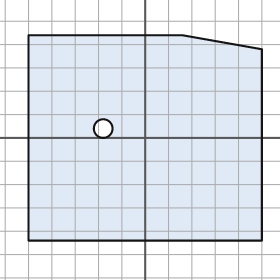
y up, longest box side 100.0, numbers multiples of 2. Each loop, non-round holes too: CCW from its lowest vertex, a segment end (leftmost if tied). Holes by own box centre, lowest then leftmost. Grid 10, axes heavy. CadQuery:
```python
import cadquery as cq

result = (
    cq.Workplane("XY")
    .moveTo(-50.0, -44.0)
    .lineTo(50.0, -44.0)
    .lineTo(50.0, 38.0)
    .lineTo(16.0, 44.0)
    .lineTo(-50.0, 44.0)
    .close()
    .moveTo(-18.0, 4.0)
    .circle(4.0)
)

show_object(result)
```